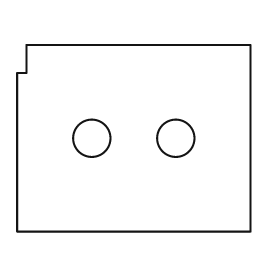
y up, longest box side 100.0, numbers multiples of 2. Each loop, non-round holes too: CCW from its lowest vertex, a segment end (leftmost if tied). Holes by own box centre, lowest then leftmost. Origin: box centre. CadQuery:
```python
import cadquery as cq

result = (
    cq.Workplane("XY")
    .moveTo(-50.0, -40.0)
    .lineTo(50.0, -40.0)
    .lineTo(50.0, 40.0)
    .lineTo(-46.0, 40.0)
    .lineTo(-46.0, 28.0)
    .lineTo(-50.0, 28.0)
    .close()
    .moveTo(-18.0, 0.0)
    .circle(8.0)
    .moveTo(18.0, 0.0)
    .circle(8.0)
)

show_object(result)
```